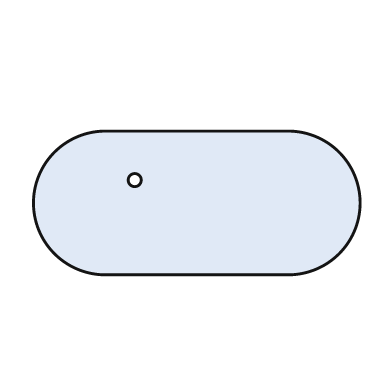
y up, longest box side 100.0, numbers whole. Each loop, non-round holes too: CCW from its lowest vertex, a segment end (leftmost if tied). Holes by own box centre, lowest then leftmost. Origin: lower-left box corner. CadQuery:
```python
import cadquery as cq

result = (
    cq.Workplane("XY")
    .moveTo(22.0, 0.0)
    .lineTo(78.0, 0.0)
    .threePointArc((100.0, 22.0), (78.0, 44.0))
    .lineTo(22.0, 44.0)
    .threePointArc((0.0, 22.0), (22.0, 0.0))
    .close()
    .moveTo(31.0, 29.0)
    .circle(2.0)
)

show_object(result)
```